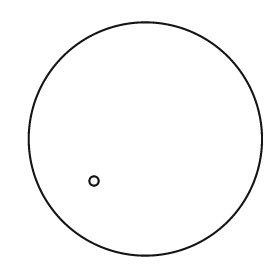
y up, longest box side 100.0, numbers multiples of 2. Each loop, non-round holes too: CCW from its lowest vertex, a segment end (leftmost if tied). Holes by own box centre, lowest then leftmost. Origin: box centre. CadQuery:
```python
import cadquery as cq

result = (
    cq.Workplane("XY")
    .moveTo(0.0, 0.0)
    .circle(50.0)
    .moveTo(-22.0, -18.0)
    .circle(2.0)
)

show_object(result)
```